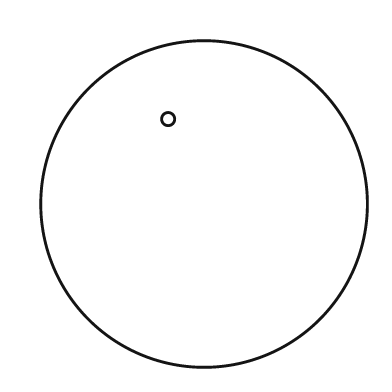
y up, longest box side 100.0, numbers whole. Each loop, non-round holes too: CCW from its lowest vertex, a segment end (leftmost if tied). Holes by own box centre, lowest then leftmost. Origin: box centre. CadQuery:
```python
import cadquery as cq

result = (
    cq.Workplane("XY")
    .moveTo(0.0, 0.0)
    .circle(50.0)
    .moveTo(-11.0, 26.0)
    .circle(2.0)
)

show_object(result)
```